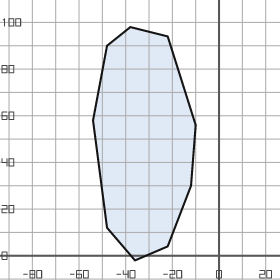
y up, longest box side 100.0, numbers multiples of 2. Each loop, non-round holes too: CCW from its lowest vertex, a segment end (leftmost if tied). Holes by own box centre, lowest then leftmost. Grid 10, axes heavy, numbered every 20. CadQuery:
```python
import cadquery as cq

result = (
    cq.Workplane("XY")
    .moveTo(-36.0, -2.0)
    .lineTo(-22.0, 4.0)
    .lineTo(-12.0, 30.0)
    .lineTo(-10.0, 56.0)
    .lineTo(-22.0, 94.0)
    .lineTo(-38.0, 98.0)
    .lineTo(-48.0, 90.0)
    .lineTo(-54.0, 58.0)
    .lineTo(-48.0, 12.0)
    .close()
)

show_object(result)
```